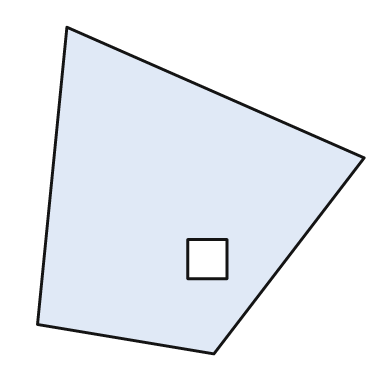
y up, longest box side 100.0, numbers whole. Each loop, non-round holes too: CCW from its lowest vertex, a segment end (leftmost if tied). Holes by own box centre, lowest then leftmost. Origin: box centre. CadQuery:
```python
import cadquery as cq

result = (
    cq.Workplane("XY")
    .moveTo(4.0, -50.0)
    .lineTo(50.0, 10.0)
    .lineTo(-41.0, 50.0)
    .lineTo(-50.0, -41.0)
    .close()
    .moveTo(-4.0, -27.0)
    .lineTo(8.0, -27.0)
    .lineTo(8.0, -15.0)
    .lineTo(-4.0, -15.0)
    .close()
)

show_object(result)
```